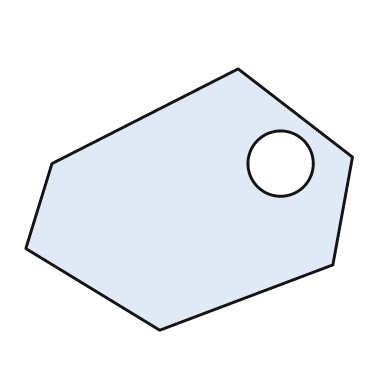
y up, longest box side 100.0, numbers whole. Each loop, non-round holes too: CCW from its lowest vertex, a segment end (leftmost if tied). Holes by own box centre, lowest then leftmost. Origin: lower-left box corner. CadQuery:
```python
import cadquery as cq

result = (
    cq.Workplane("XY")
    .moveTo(41.0, 0.0)
    .lineTo(94.0, 20.0)
    .lineTo(100.0, 53.0)
    .lineTo(65.0, 80.0)
    .lineTo(8.0, 51.0)
    .lineTo(0.0, 25.0)
    .close()
    .moveTo(78.0, 51.0)
    .circle(10.0)
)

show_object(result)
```